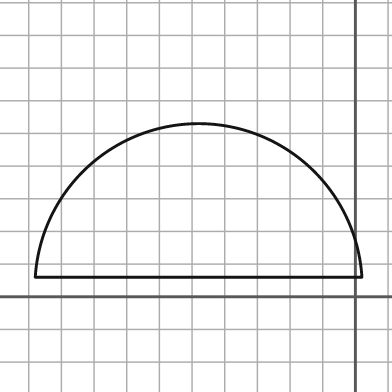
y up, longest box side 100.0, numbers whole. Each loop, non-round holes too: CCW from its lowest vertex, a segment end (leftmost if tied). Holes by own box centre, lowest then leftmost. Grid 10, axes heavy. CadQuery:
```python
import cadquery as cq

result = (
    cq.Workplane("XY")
    .moveTo(-98.0, 6.0)
    .lineTo(2.0, 6.0)
    .threePointArc((-48.0, 53.0), (-98.0, 6.0))
    .close()
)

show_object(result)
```